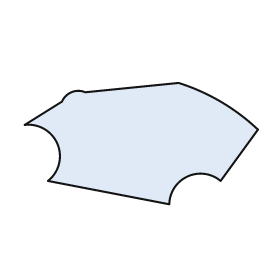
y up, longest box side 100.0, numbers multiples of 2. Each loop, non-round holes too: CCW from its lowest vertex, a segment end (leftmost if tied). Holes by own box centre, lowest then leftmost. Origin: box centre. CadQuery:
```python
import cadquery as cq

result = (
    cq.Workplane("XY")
    .moveTo(12.0, -26.0)
    .threePointArc((20.0, -14.0), (34.0, -16.0))
    .lineTo(50.0, 6.0)
    .threePointArc((34.0, 18.0), (16.0, 26.0))
    .lineTo(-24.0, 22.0)
    .threePointArc((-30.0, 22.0), (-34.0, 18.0))
    .lineTo(-50.0, 8.0)
    .threePointArc((-36.0, 0.0), (-40.0, -16.0))
    .close()
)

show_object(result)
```